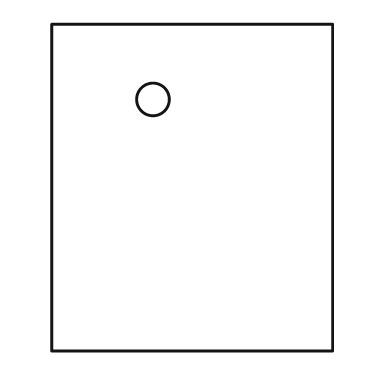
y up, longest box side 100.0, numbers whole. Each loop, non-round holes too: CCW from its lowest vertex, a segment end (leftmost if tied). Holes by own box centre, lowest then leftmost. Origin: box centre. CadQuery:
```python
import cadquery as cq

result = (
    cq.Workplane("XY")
    .moveTo(-43.0, -50.0)
    .lineTo(43.0, -50.0)
    .lineTo(43.0, 50.0)
    .lineTo(-43.0, 50.0)
    .close()
    .moveTo(-12.0, 27.0)
    .circle(5.0)
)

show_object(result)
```